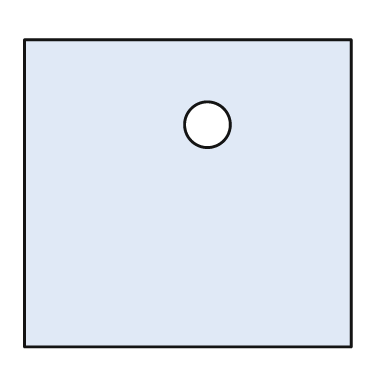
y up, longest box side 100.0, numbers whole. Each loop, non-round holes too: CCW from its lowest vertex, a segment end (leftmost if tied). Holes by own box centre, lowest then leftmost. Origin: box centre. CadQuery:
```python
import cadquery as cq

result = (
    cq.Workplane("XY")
    .moveTo(-50.0, -47.0)
    .lineTo(50.0, -47.0)
    .lineTo(50.0, 47.0)
    .lineTo(-50.0, 47.0)
    .close()
    .moveTo(6.0, 21.0)
    .circle(7.0)
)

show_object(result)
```